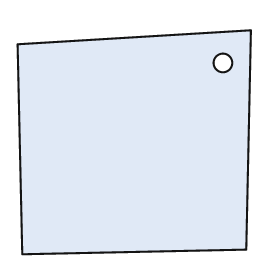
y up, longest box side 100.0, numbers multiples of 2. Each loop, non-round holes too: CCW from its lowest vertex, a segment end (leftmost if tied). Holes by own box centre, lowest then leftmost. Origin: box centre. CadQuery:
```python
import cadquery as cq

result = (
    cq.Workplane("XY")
    .moveTo(-48.0, -48.0)
    .lineTo(48.0, -46.0)
    .lineTo(50.0, 48.0)
    .lineTo(-50.0, 42.0)
    .close()
    .moveTo(38.0, 34.0)
    .circle(4.0)
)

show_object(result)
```